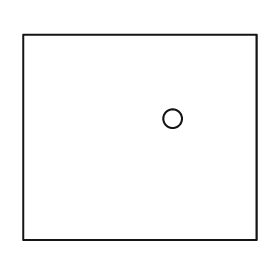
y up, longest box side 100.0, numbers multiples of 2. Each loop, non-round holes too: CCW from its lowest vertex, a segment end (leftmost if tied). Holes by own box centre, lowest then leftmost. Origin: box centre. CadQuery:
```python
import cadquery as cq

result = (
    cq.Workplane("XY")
    .moveTo(-50.0, -44.0)
    .lineTo(50.0, -44.0)
    .lineTo(50.0, 44.0)
    .lineTo(-50.0, 44.0)
    .close()
    .moveTo(14.0, 8.0)
    .circle(4.0)
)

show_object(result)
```